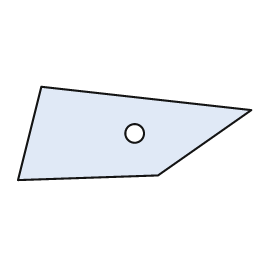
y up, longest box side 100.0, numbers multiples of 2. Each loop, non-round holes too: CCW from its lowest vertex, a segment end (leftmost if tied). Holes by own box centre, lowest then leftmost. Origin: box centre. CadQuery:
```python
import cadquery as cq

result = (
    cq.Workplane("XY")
    .moveTo(-50.0, -20.0)
    .lineTo(10.0, -18.0)
    .lineTo(50.0, 10.0)
    .lineTo(-40.0, 20.0)
    .close()
    .moveTo(0.0, 0.0)
    .circle(4.0)
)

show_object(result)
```